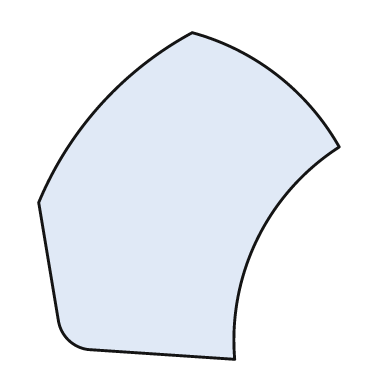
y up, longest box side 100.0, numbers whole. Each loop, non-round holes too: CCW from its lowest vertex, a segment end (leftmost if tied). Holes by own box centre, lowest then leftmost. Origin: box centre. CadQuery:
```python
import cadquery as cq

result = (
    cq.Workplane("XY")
    .moveTo(14.0, -50.0)
    .threePointArc((21.0, -13.0), (46.0, 15.0))
    .threePointArc((27.0, 37.0), (1.0, 50.0))
    .threePointArc((-27.0, 28.0), (-46.0, -2.0))
    .lineTo(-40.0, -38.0)
    .threePointArc((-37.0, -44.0), (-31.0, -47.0))
    .close()
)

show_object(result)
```